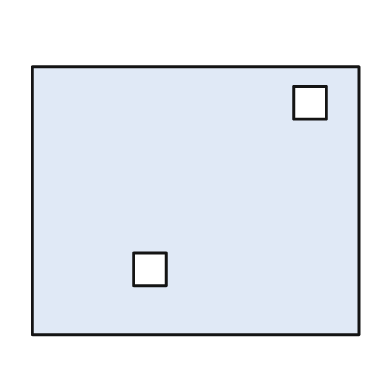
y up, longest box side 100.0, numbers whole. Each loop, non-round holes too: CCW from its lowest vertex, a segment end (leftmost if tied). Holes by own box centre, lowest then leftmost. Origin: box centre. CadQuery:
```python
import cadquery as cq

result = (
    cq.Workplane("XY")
    .moveTo(-50.0, -41.0)
    .lineTo(50.0, -41.0)
    .lineTo(50.0, 41.0)
    .lineTo(-50.0, 41.0)
    .close()
    .moveTo(-19.0, -26.0)
    .lineTo(-9.0, -26.0)
    .lineTo(-9.0, -16.0)
    .lineTo(-19.0, -16.0)
    .close()
    .moveTo(30.0, 25.0)
    .lineTo(40.0, 25.0)
    .lineTo(40.0, 35.0)
    .lineTo(30.0, 35.0)
    .close()
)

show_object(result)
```